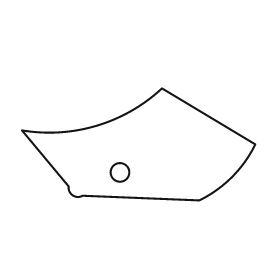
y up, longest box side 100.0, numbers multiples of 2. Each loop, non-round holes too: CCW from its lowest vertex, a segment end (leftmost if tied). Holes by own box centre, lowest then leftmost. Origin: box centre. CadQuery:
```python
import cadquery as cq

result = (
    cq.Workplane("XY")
    .moveTo(26.0, -24.0)
    .threePointArc((40.0, -14.0), (50.0, 0.0))
    .lineTo(10.0, 24.0)
    .threePointArc((-18.0, 8.0), (-50.0, 6.0))
    .lineTo(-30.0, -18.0)
    .threePointArc((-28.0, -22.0), (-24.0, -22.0))
    .close()
    .moveTo(-8.0, -12.0)
    .circle(4.0)
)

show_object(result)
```